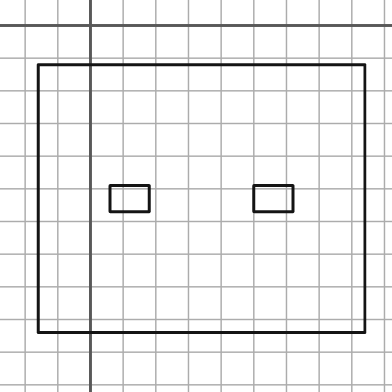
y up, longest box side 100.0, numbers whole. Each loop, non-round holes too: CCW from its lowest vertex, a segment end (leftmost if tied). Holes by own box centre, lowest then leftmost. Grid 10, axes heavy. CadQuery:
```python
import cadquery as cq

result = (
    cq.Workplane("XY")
    .moveTo(-16.0, -94.0)
    .lineTo(84.0, -94.0)
    .lineTo(84.0, -12.0)
    .lineTo(-16.0, -12.0)
    .close()
    .moveTo(6.0, -57.0)
    .lineTo(18.0, -57.0)
    .lineTo(18.0, -49.0)
    .lineTo(6.0, -49.0)
    .close()
    .moveTo(50.0, -57.0)
    .lineTo(62.0, -57.0)
    .lineTo(62.0, -49.0)
    .lineTo(50.0, -49.0)
    .close()
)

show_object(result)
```